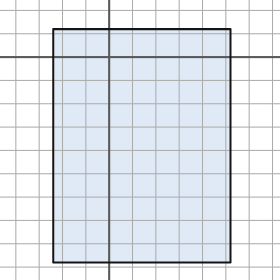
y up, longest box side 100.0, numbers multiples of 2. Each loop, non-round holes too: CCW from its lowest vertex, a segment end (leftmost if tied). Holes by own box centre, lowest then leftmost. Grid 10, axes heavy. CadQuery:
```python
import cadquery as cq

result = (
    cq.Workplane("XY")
    .moveTo(-24.0, -88.0)
    .lineTo(52.0, -88.0)
    .lineTo(52.0, 12.0)
    .lineTo(-24.0, 12.0)
    .close()
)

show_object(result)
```